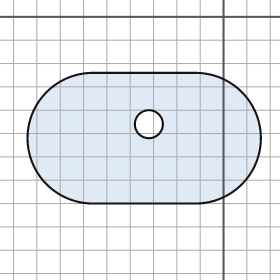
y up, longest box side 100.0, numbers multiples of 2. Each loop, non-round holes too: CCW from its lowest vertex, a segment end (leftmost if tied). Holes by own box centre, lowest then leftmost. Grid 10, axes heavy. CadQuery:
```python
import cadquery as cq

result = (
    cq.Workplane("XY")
    .moveTo(-56.0, -80.0)
    .lineTo(-12.0, -80.0)
    .threePointArc((16.0, -52.0), (-12.0, -24.0))
    .lineTo(-56.0, -24.0)
    .threePointArc((-84.0, -52.0), (-56.0, -80.0))
    .close()
    .moveTo(-32.0, -46.0)
    .circle(6.0)
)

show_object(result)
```